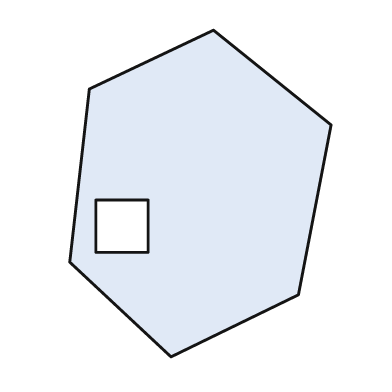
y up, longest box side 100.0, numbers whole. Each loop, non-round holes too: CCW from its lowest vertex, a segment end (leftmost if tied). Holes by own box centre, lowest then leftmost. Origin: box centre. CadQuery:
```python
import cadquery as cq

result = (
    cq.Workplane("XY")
    .moveTo(-9.0, -50.0)
    .lineTo(30.0, -31.0)
    .lineTo(40.0, 21.0)
    .lineTo(4.0, 50.0)
    .lineTo(-34.0, 32.0)
    .lineTo(-40.0, -21.0)
    .close()
    .moveTo(-32.0, -18.0)
    .lineTo(-16.0, -18.0)
    .lineTo(-16.0, -2.0)
    .lineTo(-32.0, -2.0)
    .close()
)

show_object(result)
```